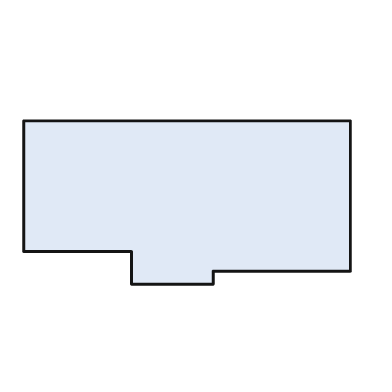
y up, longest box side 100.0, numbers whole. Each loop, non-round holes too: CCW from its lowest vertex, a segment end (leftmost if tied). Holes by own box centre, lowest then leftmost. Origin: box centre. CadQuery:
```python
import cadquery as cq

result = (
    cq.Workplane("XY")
    .moveTo(-17.0, -25.0)
    .lineTo(8.0, -25.0)
    .lineTo(8.0, -21.0)
    .lineTo(50.0, -21.0)
    .lineTo(50.0, 25.0)
    .lineTo(-50.0, 25.0)
    .lineTo(-50.0, -15.0)
    .lineTo(-17.0, -15.0)
    .close()
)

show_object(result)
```